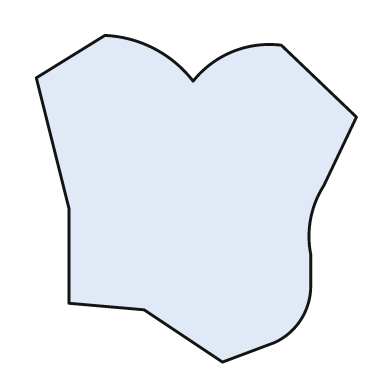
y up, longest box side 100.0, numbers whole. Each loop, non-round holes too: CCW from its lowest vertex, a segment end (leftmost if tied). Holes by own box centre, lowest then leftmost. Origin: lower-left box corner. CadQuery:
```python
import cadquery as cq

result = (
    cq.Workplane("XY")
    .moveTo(57.0, 0.0)
    .lineTo(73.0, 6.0)
    .threePointArc((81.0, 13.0), (84.0, 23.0))
    .lineTo(84.0, 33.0)
    .threePointArc((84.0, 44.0), (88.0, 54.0))
    .lineTo(98.0, 75.0)
    .lineTo(75.0, 97.0)
    .threePointArc((60.0, 95.0), (48.0, 86.0))
    .threePointArc((36.0, 96.0), (21.0, 100.0))
    .lineTo(0.0, 87.0)
    .lineTo(10.0, 47.0)
    .lineTo(10.0, 18.0)
    .lineTo(33.0, 16.0)
    .close()
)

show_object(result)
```